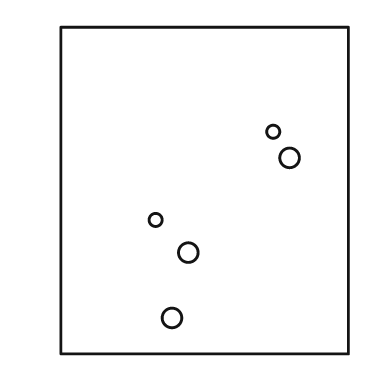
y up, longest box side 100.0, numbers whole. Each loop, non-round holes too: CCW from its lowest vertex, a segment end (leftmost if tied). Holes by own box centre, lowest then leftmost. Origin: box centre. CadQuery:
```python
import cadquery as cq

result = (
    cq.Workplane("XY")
    .moveTo(-44.0, -50.0)
    .lineTo(44.0, -50.0)
    .lineTo(44.0, 50.0)
    .lineTo(-44.0, 50.0)
    .close()
    .moveTo(-10.0, -39.0)
    .circle(3.0)
    .moveTo(-5.0, -19.0)
    .circle(3.0)
    .moveTo(-15.0, -9.0)
    .circle(2.0)
    .moveTo(26.0, 10.0)
    .circle(3.0)
    .moveTo(21.0, 18.0)
    .circle(2.0)
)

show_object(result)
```